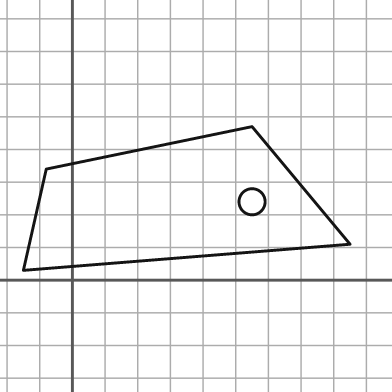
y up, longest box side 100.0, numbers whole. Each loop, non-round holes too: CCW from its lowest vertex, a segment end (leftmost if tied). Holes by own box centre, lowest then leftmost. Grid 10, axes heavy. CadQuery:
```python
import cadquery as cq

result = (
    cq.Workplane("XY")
    .moveTo(-15.0, 3.0)
    .lineTo(85.0, 11.0)
    .lineTo(55.0, 47.0)
    .lineTo(-8.0, 34.0)
    .close()
    .moveTo(55.0, 24.0)
    .circle(4.0)
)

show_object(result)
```